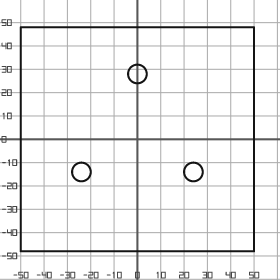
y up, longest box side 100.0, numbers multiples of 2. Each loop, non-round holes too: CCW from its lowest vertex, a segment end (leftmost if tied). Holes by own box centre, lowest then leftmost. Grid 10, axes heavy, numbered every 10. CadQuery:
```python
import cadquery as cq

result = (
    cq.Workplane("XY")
    .moveTo(-50.0, -48.0)
    .lineTo(50.0, -48.0)
    .lineTo(50.0, 48.0)
    .lineTo(-50.0, 48.0)
    .close()
    .moveTo(-24.0, -14.0)
    .circle(4.0)
    .moveTo(24.0, -14.0)
    .circle(4.0)
    .moveTo(0.0, 28.0)
    .circle(4.0)
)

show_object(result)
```